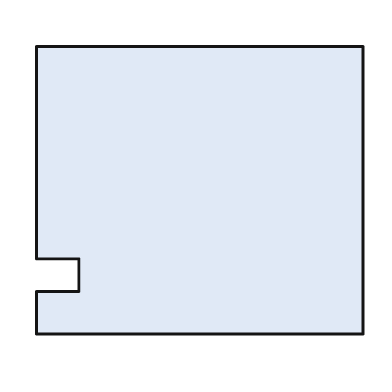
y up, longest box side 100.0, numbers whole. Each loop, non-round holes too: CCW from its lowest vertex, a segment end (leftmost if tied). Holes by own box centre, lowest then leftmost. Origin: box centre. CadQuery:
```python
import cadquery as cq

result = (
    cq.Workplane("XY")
    .moveTo(-50.0, -44.0)
    .lineTo(50.0, -44.0)
    .lineTo(50.0, 44.0)
    .lineTo(-50.0, 44.0)
    .lineTo(-50.0, -21.0)
    .lineTo(-37.0, -21.0)
    .lineTo(-37.0, -31.0)
    .lineTo(-50.0, -31.0)
    .close()
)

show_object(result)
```